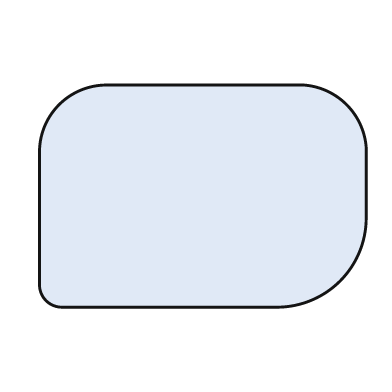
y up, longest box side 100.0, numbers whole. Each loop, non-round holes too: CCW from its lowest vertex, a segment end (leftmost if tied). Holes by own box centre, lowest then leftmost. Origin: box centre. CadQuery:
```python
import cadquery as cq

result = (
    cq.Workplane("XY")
    .moveTo(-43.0, -34.0)
    .lineTo(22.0, -34.0)
    .threePointArc((42.0, -26.0), (50.0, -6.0))
    .lineTo(50.0, 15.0)
    .threePointArc((44.0, 28.0), (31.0, 34.0))
    .lineTo(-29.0, 34.0)
    .threePointArc((-44.0, 28.0), (-50.0, 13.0))
    .lineTo(-50.0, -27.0)
    .threePointArc((-48.0, -32.0), (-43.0, -34.0))
    .close()
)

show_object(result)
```